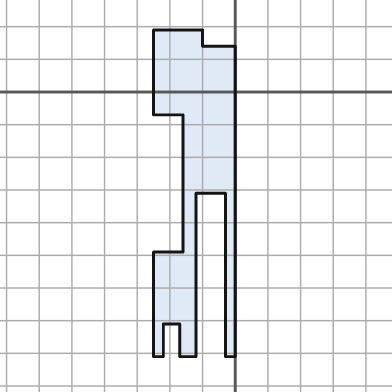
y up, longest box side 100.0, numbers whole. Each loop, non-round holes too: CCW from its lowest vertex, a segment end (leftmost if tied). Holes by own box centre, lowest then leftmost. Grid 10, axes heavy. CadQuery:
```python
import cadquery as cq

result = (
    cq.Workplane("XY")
    .moveTo(-25.0, -81.0)
    .lineTo(-22.0, -81.0)
    .lineTo(-22.0, -71.0)
    .lineTo(-17.0, -71.0)
    .lineTo(-17.0, -81.0)
    .lineTo(-12.0, -81.0)
    .lineTo(-12.0, -31.0)
    .lineTo(-3.0, -31.0)
    .lineTo(-3.0, -81.0)
    .lineTo(0.0, -81.0)
    .lineTo(0.0, 14.0)
    .lineTo(-10.0, 14.0)
    .lineTo(-10.0, 19.0)
    .lineTo(-25.0, 19.0)
    .lineTo(-25.0, -7.0)
    .lineTo(-16.0, -7.0)
    .lineTo(-16.0, -49.0)
    .lineTo(-25.0, -49.0)
    .close()
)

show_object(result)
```